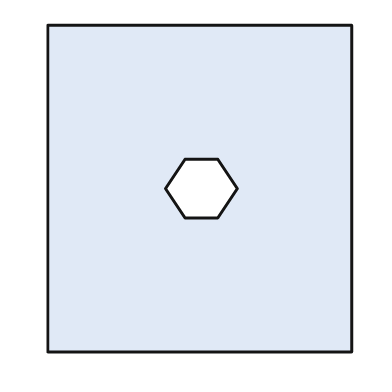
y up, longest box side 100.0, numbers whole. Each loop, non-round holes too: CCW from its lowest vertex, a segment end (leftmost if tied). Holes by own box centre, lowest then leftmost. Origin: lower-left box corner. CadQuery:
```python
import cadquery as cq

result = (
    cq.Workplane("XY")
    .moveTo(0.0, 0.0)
    .lineTo(93.0, 0.0)
    .lineTo(93.0, 100.0)
    .lineTo(0.0, 100.0)
    .close()
    .moveTo(42.0, 41.0)
    .lineTo(52.0, 41.0)
    .lineTo(58.0, 50.0)
    .lineTo(52.0, 59.0)
    .lineTo(42.0, 59.0)
    .lineTo(36.0, 50.0)
    .close()
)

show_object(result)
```